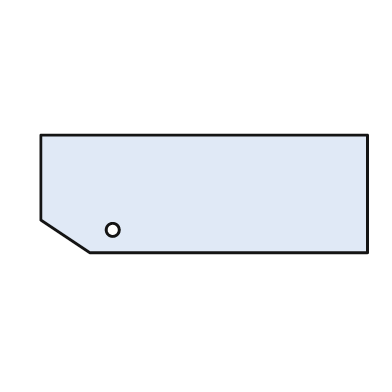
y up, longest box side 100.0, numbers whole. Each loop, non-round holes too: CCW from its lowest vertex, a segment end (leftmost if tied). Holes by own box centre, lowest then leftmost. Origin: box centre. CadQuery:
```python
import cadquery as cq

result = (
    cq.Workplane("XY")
    .moveTo(-35.0, -18.0)
    .lineTo(50.0, -18.0)
    .lineTo(50.0, 18.0)
    .lineTo(-50.0, 18.0)
    .lineTo(-50.0, -8.0)
    .close()
    .moveTo(-28.0, -11.0)
    .circle(2.0)
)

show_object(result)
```